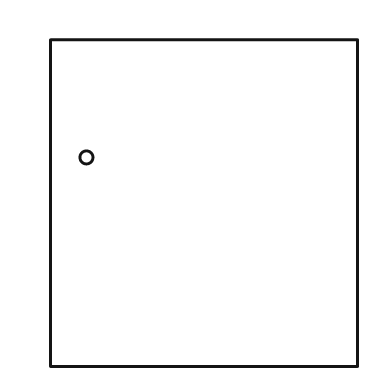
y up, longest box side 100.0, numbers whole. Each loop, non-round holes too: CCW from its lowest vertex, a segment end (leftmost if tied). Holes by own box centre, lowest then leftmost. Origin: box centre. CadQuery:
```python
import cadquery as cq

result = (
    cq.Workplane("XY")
    .moveTo(-47.0, -50.0)
    .lineTo(47.0, -50.0)
    .lineTo(47.0, 50.0)
    .lineTo(-47.0, 50.0)
    .close()
    .moveTo(-36.0, 14.0)
    .circle(2.0)
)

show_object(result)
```